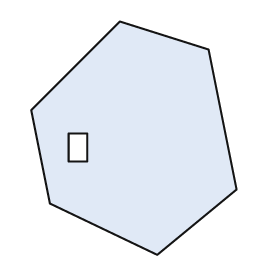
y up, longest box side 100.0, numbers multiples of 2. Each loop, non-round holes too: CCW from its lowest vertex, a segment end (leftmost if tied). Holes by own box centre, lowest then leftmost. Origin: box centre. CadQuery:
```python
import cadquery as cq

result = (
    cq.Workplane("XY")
    .moveTo(10.0, -50.0)
    .lineTo(44.0, -22.0)
    .lineTo(32.0, 38.0)
    .lineTo(-6.0, 50.0)
    .lineTo(-44.0, 12.0)
    .lineTo(-36.0, -28.0)
    .close()
    .moveTo(-28.0, -10.0)
    .lineTo(-20.0, -10.0)
    .lineTo(-20.0, 2.0)
    .lineTo(-28.0, 2.0)
    .close()
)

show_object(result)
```